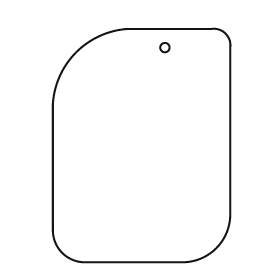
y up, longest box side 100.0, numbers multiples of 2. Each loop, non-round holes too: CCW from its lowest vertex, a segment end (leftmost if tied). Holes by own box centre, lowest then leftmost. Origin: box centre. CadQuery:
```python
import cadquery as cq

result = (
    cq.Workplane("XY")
    .moveTo(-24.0, -50.0)
    .lineTo(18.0, -50.0)
    .threePointArc((32.0, -44.0), (38.0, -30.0))
    .lineTo(38.0, 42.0)
    .threePointArc((36.0, 48.0), (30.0, 50.0))
    .lineTo(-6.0, 50.0)
    .threePointArc((-28.0, 40.0), (-38.0, 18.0))
    .lineTo(-38.0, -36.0)
    .threePointArc((-34.0, -46.0), (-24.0, -50.0))
    .close()
    .moveTo(10.0, 42.0)
    .circle(2.0)
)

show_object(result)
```